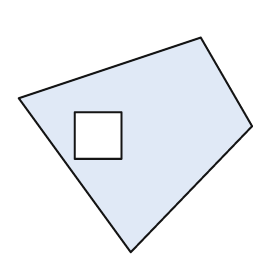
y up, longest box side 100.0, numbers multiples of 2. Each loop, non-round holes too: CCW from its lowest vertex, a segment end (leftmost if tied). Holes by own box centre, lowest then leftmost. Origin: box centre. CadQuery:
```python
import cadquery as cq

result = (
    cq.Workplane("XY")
    .moveTo(-2.0, -46.0)
    .lineTo(50.0, 8.0)
    .lineTo(28.0, 46.0)
    .lineTo(-50.0, 20.0)
    .close()
    .moveTo(-26.0, -6.0)
    .lineTo(-6.0, -6.0)
    .lineTo(-6.0, 14.0)
    .lineTo(-26.0, 14.0)
    .close()
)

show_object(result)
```